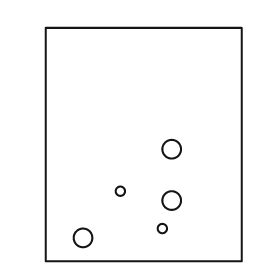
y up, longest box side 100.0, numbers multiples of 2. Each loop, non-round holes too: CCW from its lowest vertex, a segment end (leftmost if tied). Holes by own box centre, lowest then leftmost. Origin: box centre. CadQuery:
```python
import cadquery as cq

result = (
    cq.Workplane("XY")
    .moveTo(-42.0, -50.0)
    .lineTo(42.0, -50.0)
    .lineTo(42.0, 50.0)
    .lineTo(-42.0, 50.0)
    .close()
    .moveTo(-26.0, -40.0)
    .circle(4.0)
    .moveTo(8.0, -36.0)
    .circle(2.0)
    .moveTo(12.0, -24.0)
    .circle(4.0)
    .moveTo(-10.0, -20.0)
    .circle(2.0)
    .moveTo(12.0, -2.0)
    .circle(4.0)
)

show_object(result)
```